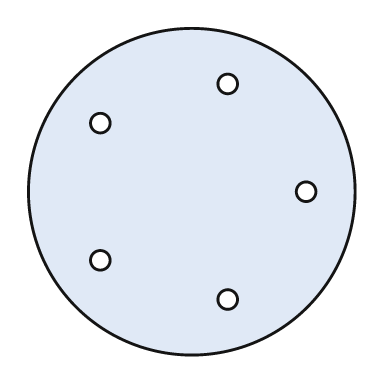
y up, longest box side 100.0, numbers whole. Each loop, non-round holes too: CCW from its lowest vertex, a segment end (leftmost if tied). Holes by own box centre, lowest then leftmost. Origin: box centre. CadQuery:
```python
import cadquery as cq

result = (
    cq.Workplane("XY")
    .moveTo(0.0, 0.0)
    .circle(50.0)
    .moveTo(11.0, -33.0)
    .circle(3.0)
    .moveTo(-28.0, -21.0)
    .circle(3.0)
    .moveTo(35.0, 0.0)
    .circle(3.0)
    .moveTo(-28.0, 21.0)
    .circle(3.0)
    .moveTo(11.0, 33.0)
    .circle(3.0)
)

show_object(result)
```